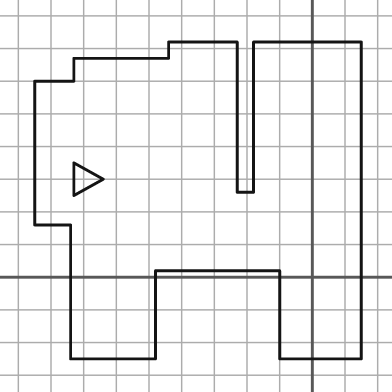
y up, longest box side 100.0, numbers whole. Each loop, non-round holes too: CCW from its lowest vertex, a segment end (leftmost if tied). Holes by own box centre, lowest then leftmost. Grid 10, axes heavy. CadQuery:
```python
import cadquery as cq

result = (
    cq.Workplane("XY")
    .moveTo(-74.0, -25.0)
    .lineTo(-48.0, -25.0)
    .lineTo(-48.0, 2.0)
    .lineTo(-10.0, 2.0)
    .lineTo(-10.0, -25.0)
    .lineTo(15.0, -25.0)
    .lineTo(15.0, 72.0)
    .lineTo(-18.0, 72.0)
    .lineTo(-18.0, 26.0)
    .lineTo(-23.0, 26.0)
    .lineTo(-23.0, 72.0)
    .lineTo(-44.0, 72.0)
    .lineTo(-44.0, 67.0)
    .lineTo(-73.0, 67.0)
    .lineTo(-73.0, 60.0)
    .lineTo(-85.0, 60.0)
    .lineTo(-85.0, 16.0)
    .lineTo(-74.0, 16.0)
    .close()
    .moveTo(-73.0, 25.0)
    .lineTo(-64.0, 30.0)
    .lineTo(-73.0, 35.0)
    .close()
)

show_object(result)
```